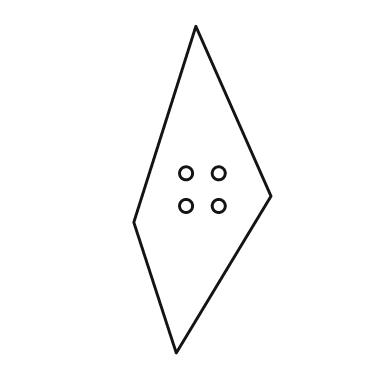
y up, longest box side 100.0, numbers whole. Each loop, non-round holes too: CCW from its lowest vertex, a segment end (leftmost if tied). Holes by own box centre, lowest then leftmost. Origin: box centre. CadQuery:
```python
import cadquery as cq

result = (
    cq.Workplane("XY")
    .moveTo(-8.0, -50.0)
    .lineTo(21.0, -2.0)
    .lineTo(-2.0, 50.0)
    .lineTo(-21.0, -10.0)
    .close()
    .moveTo(-5.0, -5.0)
    .circle(2.0)
    .moveTo(5.0, -5.0)
    .circle(2.0)
    .moveTo(-5.0, 5.0)
    .circle(2.0)
    .moveTo(5.0, 5.0)
    .circle(2.0)
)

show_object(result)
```